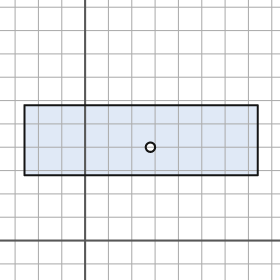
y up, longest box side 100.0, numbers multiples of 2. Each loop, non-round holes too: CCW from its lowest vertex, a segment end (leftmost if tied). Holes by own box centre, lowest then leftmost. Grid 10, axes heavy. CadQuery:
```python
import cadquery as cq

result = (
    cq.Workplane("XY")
    .moveTo(-26.0, 28.0)
    .lineTo(74.0, 28.0)
    .lineTo(74.0, 58.0)
    .lineTo(-26.0, 58.0)
    .close()
    .moveTo(28.0, 40.0)
    .circle(2.0)
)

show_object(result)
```